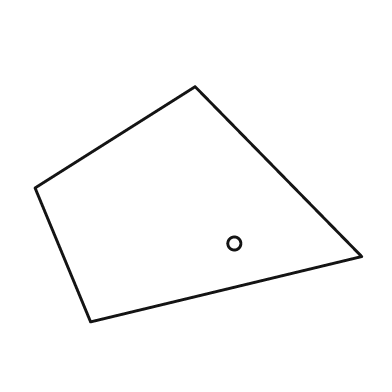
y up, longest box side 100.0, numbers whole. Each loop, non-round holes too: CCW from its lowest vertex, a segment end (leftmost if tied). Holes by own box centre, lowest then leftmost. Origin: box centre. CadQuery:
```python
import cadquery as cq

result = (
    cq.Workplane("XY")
    .moveTo(-33.0, -36.0)
    .lineTo(50.0, -16.0)
    .lineTo(-1.0, 36.0)
    .lineTo(-50.0, 5.0)
    .close()
    .moveTo(11.0, -12.0)
    .circle(2.0)
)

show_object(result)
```